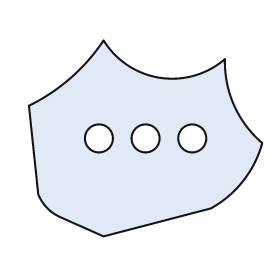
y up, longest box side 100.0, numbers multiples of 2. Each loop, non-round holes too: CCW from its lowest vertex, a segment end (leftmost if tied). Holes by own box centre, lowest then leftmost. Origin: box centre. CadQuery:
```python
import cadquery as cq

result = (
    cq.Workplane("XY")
    .moveTo(-18.0, -42.0)
    .lineTo(28.0, -30.0)
    .threePointArc((42.0, -18.0), (50.0, -2.0))
    .threePointArc((38.0, 14.0), (34.0, 34.0))
    .threePointArc((6.0, 26.0), (-18.0, 42.0))
    .threePointArc((-32.0, 26.0), (-50.0, 14.0))
    .lineTo(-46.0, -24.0)
    .threePointArc((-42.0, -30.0), (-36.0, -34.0))
    .close()
    .moveTo(-20.0, 0.0)
    .circle(6.0)
    .moveTo(0.0, 0.0)
    .circle(6.0)
    .moveTo(20.0, 0.0)
    .circle(6.0)
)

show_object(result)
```